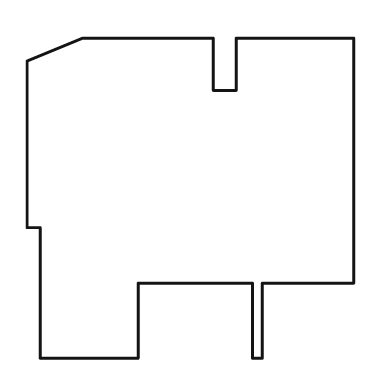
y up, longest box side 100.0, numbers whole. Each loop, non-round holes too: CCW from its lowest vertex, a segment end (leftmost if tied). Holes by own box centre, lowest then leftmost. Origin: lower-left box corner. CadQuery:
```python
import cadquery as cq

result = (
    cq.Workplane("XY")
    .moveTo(4.0, 0.0)
    .lineTo(34.0, 0.0)
    .lineTo(34.0, 23.0)
    .lineTo(69.0, 23.0)
    .lineTo(69.0, 0.0)
    .lineTo(72.0, 0.0)
    .lineTo(72.0, 23.0)
    .lineTo(100.0, 23.0)
    .lineTo(100.0, 98.0)
    .lineTo(64.0, 98.0)
    .lineTo(64.0, 82.0)
    .lineTo(57.0, 82.0)
    .lineTo(57.0, 98.0)
    .lineTo(17.0, 98.0)
    .lineTo(0.0, 91.0)
    .lineTo(0.0, 40.0)
    .lineTo(4.0, 40.0)
    .close()
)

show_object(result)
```